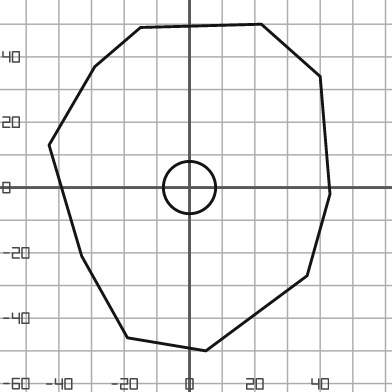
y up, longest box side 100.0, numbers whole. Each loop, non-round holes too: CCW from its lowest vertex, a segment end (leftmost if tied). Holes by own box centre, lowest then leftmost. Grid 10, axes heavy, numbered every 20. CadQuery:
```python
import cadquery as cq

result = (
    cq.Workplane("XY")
    .moveTo(5.0, -50.0)
    .lineTo(36.0, -27.0)
    .lineTo(43.0, -2.0)
    .lineTo(40.0, 34.0)
    .lineTo(22.0, 50.0)
    .lineTo(-15.0, 49.0)
    .lineTo(-29.0, 37.0)
    .lineTo(-43.0, 13.0)
    .lineTo(-33.0, -21.0)
    .lineTo(-19.0, -46.0)
    .close()
    .moveTo(0.0, 0.0)
    .circle(8.0)
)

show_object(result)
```